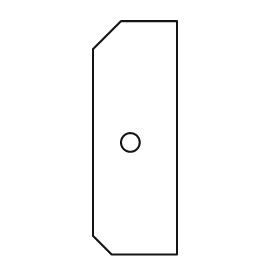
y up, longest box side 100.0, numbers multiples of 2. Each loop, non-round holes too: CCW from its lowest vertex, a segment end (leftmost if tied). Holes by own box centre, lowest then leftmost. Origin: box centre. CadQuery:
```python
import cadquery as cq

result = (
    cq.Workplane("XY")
    .moveTo(-10.0, -50.0)
    .lineTo(18.0, -50.0)
    .lineTo(18.0, 50.0)
    .lineTo(-6.0, 50.0)
    .lineTo(-18.0, 38.0)
    .lineTo(-18.0, -42.0)
    .close()
    .moveTo(-2.0, -2.0)
    .circle(4.0)
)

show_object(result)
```